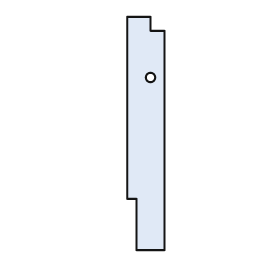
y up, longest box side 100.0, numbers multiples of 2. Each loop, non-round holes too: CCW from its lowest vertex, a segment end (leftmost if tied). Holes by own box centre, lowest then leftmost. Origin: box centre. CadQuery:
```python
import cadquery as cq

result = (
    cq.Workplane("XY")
    .moveTo(-4.0, -50.0)
    .lineTo(8.0, -50.0)
    .lineTo(8.0, 44.0)
    .lineTo(2.0, 44.0)
    .lineTo(2.0, 50.0)
    .lineTo(-8.0, 50.0)
    .lineTo(-8.0, -28.0)
    .lineTo(-4.0, -28.0)
    .close()
    .moveTo(2.0, 24.0)
    .circle(2.0)
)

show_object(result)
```